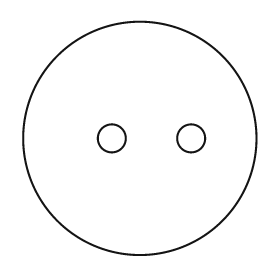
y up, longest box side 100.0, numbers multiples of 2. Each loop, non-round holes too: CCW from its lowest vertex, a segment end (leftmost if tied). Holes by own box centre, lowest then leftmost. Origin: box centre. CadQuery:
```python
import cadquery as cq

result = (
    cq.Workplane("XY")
    .moveTo(0.0, 0.0)
    .circle(50.0)
    .moveTo(-12.0, 0.0)
    .circle(6.0)
    .moveTo(22.0, 0.0)
    .circle(6.0)
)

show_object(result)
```